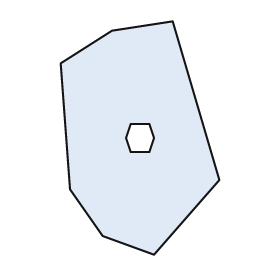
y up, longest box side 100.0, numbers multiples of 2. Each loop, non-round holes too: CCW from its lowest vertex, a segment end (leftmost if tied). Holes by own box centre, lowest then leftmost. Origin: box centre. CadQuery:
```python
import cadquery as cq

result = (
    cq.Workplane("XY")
    .moveTo(6.0, -50.0)
    .lineTo(34.0, -18.0)
    .lineTo(14.0, 50.0)
    .lineTo(-12.0, 46.0)
    .lineTo(-34.0, 32.0)
    .lineTo(-30.0, -22.0)
    .lineTo(-16.0, -42.0)
    .close()
    .moveTo(-4.0, -6.0)
    .lineTo(4.0, -6.0)
    .lineTo(6.0, 0.0)
    .lineTo(4.0, 6.0)
    .lineTo(-4.0, 6.0)
    .lineTo(-6.0, 0.0)
    .close()
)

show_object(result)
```